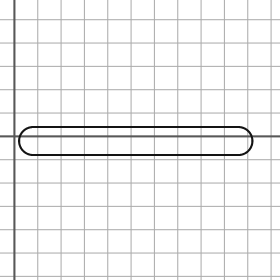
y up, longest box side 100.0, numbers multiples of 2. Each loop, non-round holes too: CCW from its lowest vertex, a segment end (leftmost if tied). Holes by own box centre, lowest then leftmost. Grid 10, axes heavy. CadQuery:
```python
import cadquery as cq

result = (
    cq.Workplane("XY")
    .moveTo(8.0, -8.0)
    .lineTo(96.0, -8.0)
    .threePointArc((102.0, -2.0), (96.0, 4.0))
    .lineTo(8.0, 4.0)
    .threePointArc((2.0, -2.0), (8.0, -8.0))
    .close()
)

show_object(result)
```